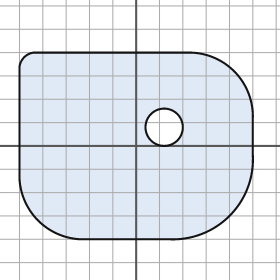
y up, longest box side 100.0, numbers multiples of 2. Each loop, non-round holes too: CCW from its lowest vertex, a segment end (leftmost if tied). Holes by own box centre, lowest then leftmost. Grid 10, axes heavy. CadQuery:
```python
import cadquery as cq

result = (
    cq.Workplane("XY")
    .moveTo(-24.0, -40.0)
    .lineTo(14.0, -40.0)
    .threePointArc((40.0, -30.0), (50.0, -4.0))
    .lineTo(50.0, 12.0)
    .threePointArc((42.0, 32.0), (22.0, 40.0))
    .lineTo(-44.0, 40.0)
    .threePointArc((-48.0, 38.0), (-50.0, 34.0))
    .lineTo(-50.0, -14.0)
    .threePointArc((-42.0, -32.0), (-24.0, -40.0))
    .close()
    .moveTo(12.0, 8.0)
    .circle(8.0)
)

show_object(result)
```